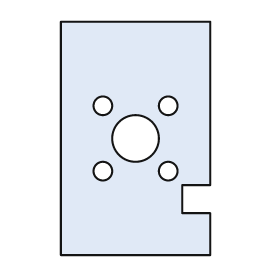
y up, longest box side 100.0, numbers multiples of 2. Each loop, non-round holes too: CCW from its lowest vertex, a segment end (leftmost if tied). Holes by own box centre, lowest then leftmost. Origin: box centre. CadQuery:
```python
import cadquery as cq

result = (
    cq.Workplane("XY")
    .moveTo(-32.0, -50.0)
    .lineTo(32.0, -50.0)
    .lineTo(32.0, -32.0)
    .lineTo(20.0, -32.0)
    .lineTo(20.0, -20.0)
    .lineTo(32.0, -20.0)
    .lineTo(32.0, 50.0)
    .lineTo(-32.0, 50.0)
    .close()
    .moveTo(-14.0, -14.0)
    .circle(4.0)
    .moveTo(14.0, -14.0)
    .circle(4.0)
    .moveTo(0.0, 0.0)
    .circle(10.0)
    .moveTo(-14.0, 14.0)
    .circle(4.0)
    .moveTo(14.0, 14.0)
    .circle(4.0)
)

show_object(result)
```